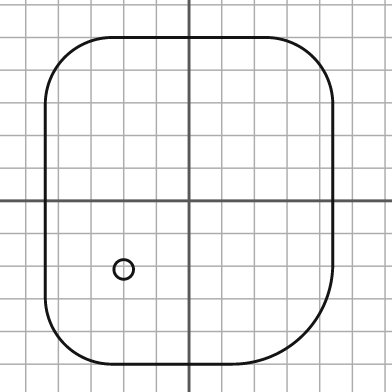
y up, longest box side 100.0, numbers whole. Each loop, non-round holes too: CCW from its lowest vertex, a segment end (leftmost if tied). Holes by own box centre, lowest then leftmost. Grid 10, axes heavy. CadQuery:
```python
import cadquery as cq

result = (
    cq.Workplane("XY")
    .moveTo(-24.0, -50.0)
    .lineTo(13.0, -50.0)
    .threePointArc((35.0, -41.0), (44.0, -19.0))
    .lineTo(44.0, 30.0)
    .threePointArc((38.0, 44.0), (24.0, 50.0))
    .lineTo(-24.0, 50.0)
    .threePointArc((-38.0, 44.0), (-44.0, 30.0))
    .lineTo(-44.0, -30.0)
    .threePointArc((-38.0, -44.0), (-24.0, -50.0))
    .close()
    .moveTo(-20.0, -21.0)
    .circle(3.0)
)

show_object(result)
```